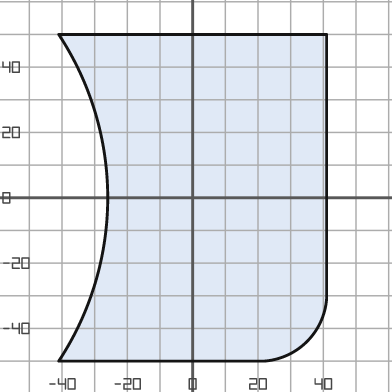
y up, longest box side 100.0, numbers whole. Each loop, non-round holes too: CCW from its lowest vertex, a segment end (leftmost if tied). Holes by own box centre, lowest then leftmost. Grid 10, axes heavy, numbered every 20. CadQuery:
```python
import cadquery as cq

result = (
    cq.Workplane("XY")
    .moveTo(-41.0, -50.0)
    .lineTo(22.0, -50.0)
    .threePointArc((35.0, -44.0), (41.0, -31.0))
    .lineTo(41.0, 50.0)
    .lineTo(-41.0, 50.0)
    .threePointArc((-26.0, 0.0), (-41.0, -50.0))
    .close()
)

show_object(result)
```